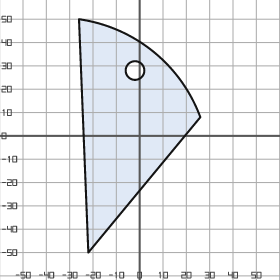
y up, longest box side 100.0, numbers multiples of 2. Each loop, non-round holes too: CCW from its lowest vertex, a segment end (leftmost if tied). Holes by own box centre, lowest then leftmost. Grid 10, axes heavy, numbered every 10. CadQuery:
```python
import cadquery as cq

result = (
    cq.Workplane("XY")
    .moveTo(-22.0, -50.0)
    .lineTo(26.0, 8.0)
    .threePointArc((6.0, 36.0), (-26.0, 50.0))
    .close()
    .moveTo(-2.0, 28.0)
    .circle(4.0)
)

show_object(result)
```